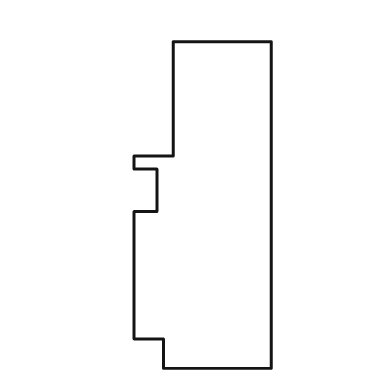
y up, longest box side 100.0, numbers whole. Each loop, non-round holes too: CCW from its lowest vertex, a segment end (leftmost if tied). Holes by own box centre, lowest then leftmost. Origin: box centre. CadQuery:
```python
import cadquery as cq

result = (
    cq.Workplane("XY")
    .moveTo(-12.0, -50.0)
    .lineTo(21.0, -50.0)
    .lineTo(21.0, 50.0)
    .lineTo(-9.0, 50.0)
    .lineTo(-9.0, 15.0)
    .lineTo(-21.0, 15.0)
    .lineTo(-21.0, 11.0)
    .lineTo(-14.0, 11.0)
    .lineTo(-14.0, -2.0)
    .lineTo(-21.0, -2.0)
    .lineTo(-21.0, -41.0)
    .lineTo(-12.0, -41.0)
    .close()
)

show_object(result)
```